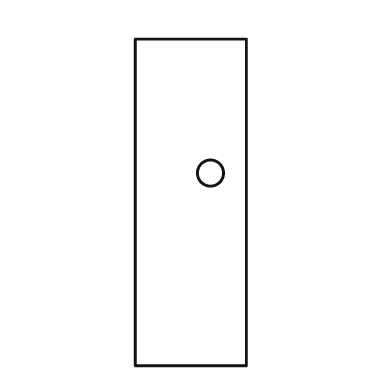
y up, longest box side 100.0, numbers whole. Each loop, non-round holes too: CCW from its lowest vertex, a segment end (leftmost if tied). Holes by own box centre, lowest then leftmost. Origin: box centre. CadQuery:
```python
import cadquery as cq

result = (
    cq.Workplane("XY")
    .moveTo(-17.0, -50.0)
    .lineTo(17.0, -50.0)
    .lineTo(17.0, 50.0)
    .lineTo(-17.0, 50.0)
    .close()
    .moveTo(6.0, 9.0)
    .circle(4.0)
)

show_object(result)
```